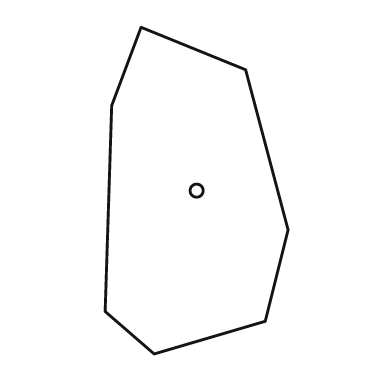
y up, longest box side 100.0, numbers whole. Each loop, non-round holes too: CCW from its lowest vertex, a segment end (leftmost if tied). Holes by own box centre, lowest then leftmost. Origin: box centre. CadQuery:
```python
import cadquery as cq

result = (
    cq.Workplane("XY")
    .moveTo(-13.0, -50.0)
    .lineTo(21.0, -40.0)
    .lineTo(28.0, -12.0)
    .lineTo(15.0, 37.0)
    .lineTo(-17.0, 50.0)
    .lineTo(-26.0, 26.0)
    .lineTo(-28.0, -37.0)
    .close()
    .moveTo(0.0, 0.0)
    .circle(2.0)
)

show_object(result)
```